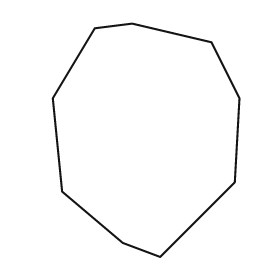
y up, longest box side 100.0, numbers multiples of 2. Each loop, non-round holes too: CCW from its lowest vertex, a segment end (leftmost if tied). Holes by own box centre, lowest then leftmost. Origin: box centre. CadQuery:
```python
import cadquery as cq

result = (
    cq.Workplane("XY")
    .moveTo(6.0, -50.0)
    .lineTo(38.0, -18.0)
    .lineTo(40.0, 18.0)
    .lineTo(28.0, 42.0)
    .lineTo(-6.0, 50.0)
    .lineTo(-22.0, 48.0)
    .lineTo(-40.0, 18.0)
    .lineTo(-36.0, -22.0)
    .lineTo(-10.0, -44.0)
    .close()
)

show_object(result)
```